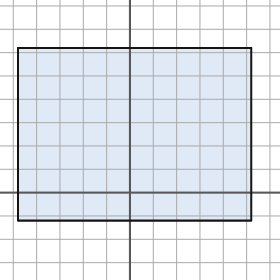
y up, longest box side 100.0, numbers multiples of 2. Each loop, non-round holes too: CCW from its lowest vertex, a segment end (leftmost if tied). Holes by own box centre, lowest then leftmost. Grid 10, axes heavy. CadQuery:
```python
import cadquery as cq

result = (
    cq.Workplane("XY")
    .moveTo(-48.0, -12.0)
    .lineTo(52.0, -12.0)
    .lineTo(52.0, 62.0)
    .lineTo(-48.0, 62.0)
    .close()
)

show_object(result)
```